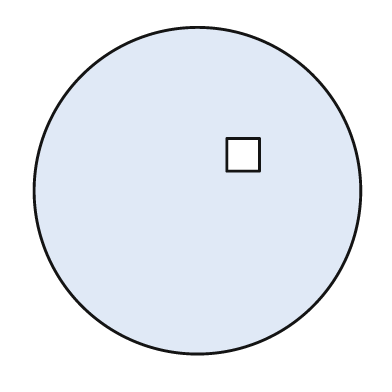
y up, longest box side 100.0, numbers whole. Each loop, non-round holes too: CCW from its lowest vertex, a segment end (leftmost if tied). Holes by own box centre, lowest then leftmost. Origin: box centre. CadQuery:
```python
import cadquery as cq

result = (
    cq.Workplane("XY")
    .moveTo(0.0, 0.0)
    .circle(50.0)
    .moveTo(9.0, 6.0)
    .lineTo(19.0, 6.0)
    .lineTo(19.0, 16.0)
    .lineTo(9.0, 16.0)
    .close()
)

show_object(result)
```